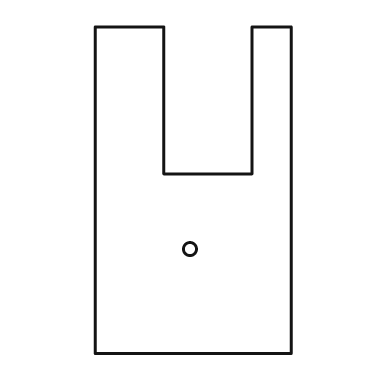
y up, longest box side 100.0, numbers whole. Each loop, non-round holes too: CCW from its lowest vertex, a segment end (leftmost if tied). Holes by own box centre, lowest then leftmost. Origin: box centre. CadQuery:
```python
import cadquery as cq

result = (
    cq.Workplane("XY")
    .moveTo(-30.0, -50.0)
    .lineTo(30.0, -50.0)
    .lineTo(30.0, 50.0)
    .lineTo(18.0, 50.0)
    .lineTo(18.0, 5.0)
    .lineTo(-9.0, 5.0)
    .lineTo(-9.0, 50.0)
    .lineTo(-30.0, 50.0)
    .close()
    .moveTo(-1.0, -18.0)
    .circle(2.0)
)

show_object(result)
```